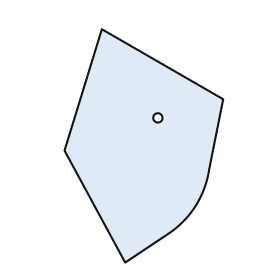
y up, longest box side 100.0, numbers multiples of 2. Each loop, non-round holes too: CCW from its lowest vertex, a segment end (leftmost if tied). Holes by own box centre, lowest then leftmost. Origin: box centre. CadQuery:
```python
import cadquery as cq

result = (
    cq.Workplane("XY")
    .moveTo(-8.0, -50.0)
    .lineTo(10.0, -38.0)
    .threePointArc((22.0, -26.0), (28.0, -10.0))
    .lineTo(34.0, 20.0)
    .lineTo(-18.0, 50.0)
    .lineTo(-34.0, -2.0)
    .close()
    .moveTo(6.0, 12.0)
    .circle(2.0)
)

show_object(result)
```